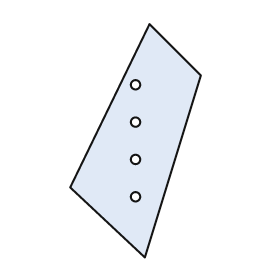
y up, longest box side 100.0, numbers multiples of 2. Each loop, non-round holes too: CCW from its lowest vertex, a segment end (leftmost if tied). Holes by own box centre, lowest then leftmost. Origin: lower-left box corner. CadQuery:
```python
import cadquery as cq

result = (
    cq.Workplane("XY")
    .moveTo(32.0, 0.0)
    .lineTo(56.0, 78.0)
    .lineTo(34.0, 100.0)
    .lineTo(0.0, 30.0)
    .close()
    .moveTo(28.0, 26.0)
    .circle(2.0)
    .moveTo(28.0, 42.0)
    .circle(2.0)
    .moveTo(28.0, 58.0)
    .circle(2.0)
    .moveTo(28.0, 74.0)
    .circle(2.0)
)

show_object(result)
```